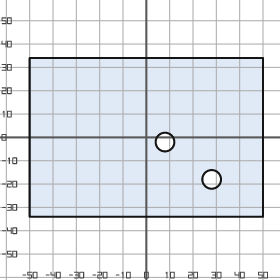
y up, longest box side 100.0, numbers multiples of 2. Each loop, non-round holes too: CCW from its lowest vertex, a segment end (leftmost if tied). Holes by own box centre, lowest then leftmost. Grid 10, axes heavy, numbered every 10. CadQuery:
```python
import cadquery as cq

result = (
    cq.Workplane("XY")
    .moveTo(-50.0, -34.0)
    .lineTo(50.0, -34.0)
    .lineTo(50.0, 34.0)
    .lineTo(-50.0, 34.0)
    .close()
    .moveTo(28.0, -18.0)
    .circle(4.0)
    .moveTo(8.0, -2.0)
    .circle(4.0)
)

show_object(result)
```